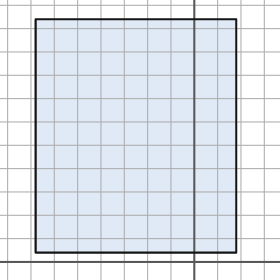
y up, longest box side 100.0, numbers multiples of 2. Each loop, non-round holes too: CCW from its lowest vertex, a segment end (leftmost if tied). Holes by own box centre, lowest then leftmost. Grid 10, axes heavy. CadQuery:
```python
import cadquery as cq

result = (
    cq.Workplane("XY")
    .moveTo(-68.0, 4.0)
    .lineTo(18.0, 4.0)
    .lineTo(18.0, 104.0)
    .lineTo(-68.0, 104.0)
    .close()
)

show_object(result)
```